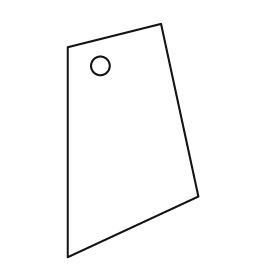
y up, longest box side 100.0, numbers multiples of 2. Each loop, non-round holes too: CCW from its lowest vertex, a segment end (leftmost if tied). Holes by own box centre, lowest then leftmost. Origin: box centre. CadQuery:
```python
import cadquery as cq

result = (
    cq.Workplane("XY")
    .moveTo(-28.0, -50.0)
    .lineTo(28.0, -24.0)
    .lineTo(12.0, 50.0)
    .lineTo(-28.0, 40.0)
    .close()
    .moveTo(-14.0, 32.0)
    .circle(4.0)
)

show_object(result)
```